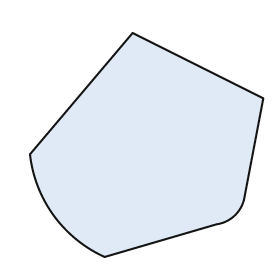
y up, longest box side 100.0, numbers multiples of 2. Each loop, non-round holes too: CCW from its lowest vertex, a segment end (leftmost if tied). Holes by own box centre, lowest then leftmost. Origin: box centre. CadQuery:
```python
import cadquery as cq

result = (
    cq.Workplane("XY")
    .moveTo(-18.0, -48.0)
    .lineTo(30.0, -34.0)
    .threePointArc((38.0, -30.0), (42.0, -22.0))
    .lineTo(50.0, 20.0)
    .lineTo(-6.0, 48.0)
    .lineTo(-50.0, -4.0)
    .threePointArc((-40.0, -30.0), (-18.0, -48.0))
    .close()
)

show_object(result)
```